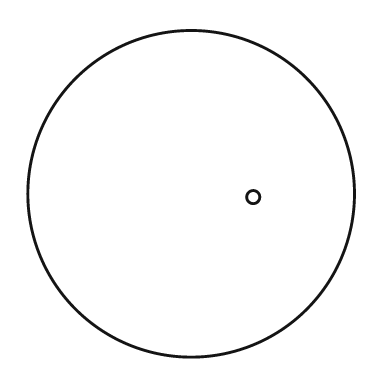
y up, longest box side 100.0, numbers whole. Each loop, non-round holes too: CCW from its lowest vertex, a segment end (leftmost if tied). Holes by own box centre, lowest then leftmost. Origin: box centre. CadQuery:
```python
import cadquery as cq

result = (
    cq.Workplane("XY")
    .moveTo(0.0, 0.0)
    .circle(50.0)
    .moveTo(19.0, -1.0)
    .circle(2.0)
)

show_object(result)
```